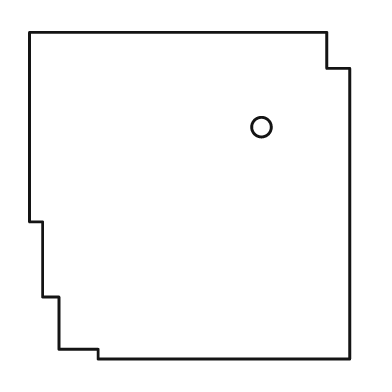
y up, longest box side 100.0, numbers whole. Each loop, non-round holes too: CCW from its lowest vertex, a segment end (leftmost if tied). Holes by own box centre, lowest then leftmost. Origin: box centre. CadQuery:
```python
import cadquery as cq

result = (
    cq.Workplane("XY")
    .moveTo(-28.0, -50.0)
    .lineTo(49.0, -50.0)
    .lineTo(49.0, 39.0)
    .lineTo(42.0, 39.0)
    .lineTo(42.0, 50.0)
    .lineTo(-49.0, 50.0)
    .lineTo(-49.0, -8.0)
    .lineTo(-45.0, -8.0)
    .lineTo(-45.0, -31.0)
    .lineTo(-40.0, -31.0)
    .lineTo(-40.0, -47.0)
    .lineTo(-28.0, -47.0)
    .close()
    .moveTo(22.0, 21.0)
    .circle(3.0)
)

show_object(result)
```